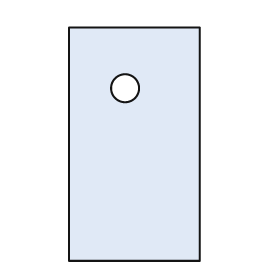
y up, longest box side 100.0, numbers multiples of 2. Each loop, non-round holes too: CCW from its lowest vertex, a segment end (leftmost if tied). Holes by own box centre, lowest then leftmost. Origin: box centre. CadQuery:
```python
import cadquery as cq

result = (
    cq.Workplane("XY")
    .moveTo(-28.0, -50.0)
    .lineTo(28.0, -50.0)
    .lineTo(28.0, 50.0)
    .lineTo(-28.0, 50.0)
    .close()
    .moveTo(-4.0, 24.0)
    .circle(6.0)
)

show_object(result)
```